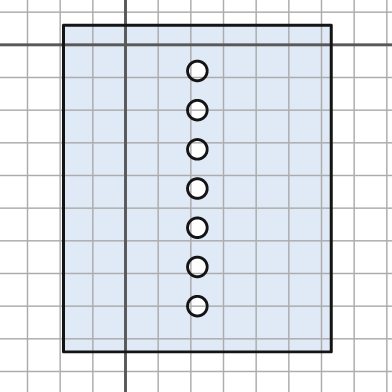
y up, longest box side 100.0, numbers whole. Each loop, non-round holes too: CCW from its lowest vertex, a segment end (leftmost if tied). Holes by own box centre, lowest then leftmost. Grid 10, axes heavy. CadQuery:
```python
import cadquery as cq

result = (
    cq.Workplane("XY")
    .moveTo(-19.0, -94.0)
    .lineTo(63.0, -94.0)
    .lineTo(63.0, 6.0)
    .lineTo(-19.0, 6.0)
    .close()
    .moveTo(22.0, -80.0)
    .circle(3.0)
    .moveTo(22.0, -68.0)
    .circle(3.0)
    .moveTo(22.0, -56.0)
    .circle(3.0)
    .moveTo(22.0, -44.0)
    .circle(3.0)
    .moveTo(22.0, -32.0)
    .circle(3.0)
    .moveTo(22.0, -20.0)
    .circle(3.0)
    .moveTo(22.0, -8.0)
    .circle(3.0)
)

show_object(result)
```